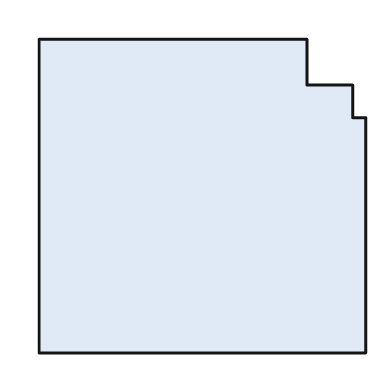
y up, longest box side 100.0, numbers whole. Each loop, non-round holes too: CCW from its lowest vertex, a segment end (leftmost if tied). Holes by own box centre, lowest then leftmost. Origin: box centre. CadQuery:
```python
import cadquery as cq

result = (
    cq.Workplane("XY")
    .moveTo(-50.0, -48.0)
    .lineTo(50.0, -48.0)
    .lineTo(50.0, 24.0)
    .lineTo(46.0, 24.0)
    .lineTo(46.0, 34.0)
    .lineTo(32.0, 34.0)
    .lineTo(32.0, 48.0)
    .lineTo(-50.0, 48.0)
    .close()
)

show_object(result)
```